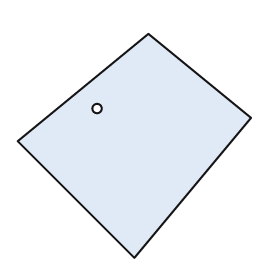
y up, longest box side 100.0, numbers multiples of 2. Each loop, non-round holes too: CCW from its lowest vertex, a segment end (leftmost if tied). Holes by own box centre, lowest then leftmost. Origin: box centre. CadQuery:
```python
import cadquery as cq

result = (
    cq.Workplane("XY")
    .moveTo(0.0, -48.0)
    .lineTo(50.0, 12.0)
    .lineTo(6.0, 48.0)
    .lineTo(-50.0, 2.0)
    .close()
    .moveTo(-16.0, 16.0)
    .circle(2.0)
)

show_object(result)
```